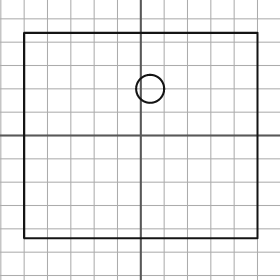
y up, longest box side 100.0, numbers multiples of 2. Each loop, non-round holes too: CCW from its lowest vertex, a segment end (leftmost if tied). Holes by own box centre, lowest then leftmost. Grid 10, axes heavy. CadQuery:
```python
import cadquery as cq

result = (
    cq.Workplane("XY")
    .moveTo(-50.0, -44.0)
    .lineTo(50.0, -44.0)
    .lineTo(50.0, 44.0)
    .lineTo(-50.0, 44.0)
    .close()
    .moveTo(4.0, 20.0)
    .circle(6.0)
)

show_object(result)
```